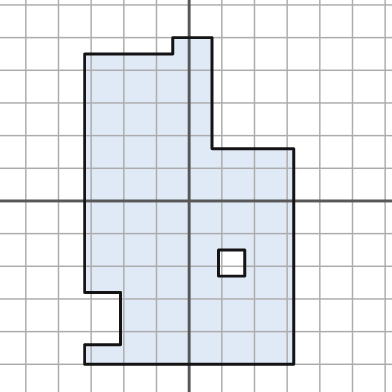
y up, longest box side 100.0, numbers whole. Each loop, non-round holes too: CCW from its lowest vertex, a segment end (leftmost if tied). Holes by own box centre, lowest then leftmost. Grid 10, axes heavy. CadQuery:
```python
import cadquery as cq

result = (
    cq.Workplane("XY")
    .moveTo(-32.0, -50.0)
    .lineTo(32.0, -50.0)
    .lineTo(32.0, 16.0)
    .lineTo(7.0, 16.0)
    .lineTo(7.0, 50.0)
    .lineTo(-5.0, 50.0)
    .lineTo(-5.0, 45.0)
    .lineTo(-32.0, 45.0)
    .lineTo(-32.0, -28.0)
    .lineTo(-21.0, -28.0)
    .lineTo(-21.0, -44.0)
    .lineTo(-32.0, -44.0)
    .close()
    .moveTo(9.0, -23.0)
    .lineTo(17.0, -23.0)
    .lineTo(17.0, -15.0)
    .lineTo(9.0, -15.0)
    .close()
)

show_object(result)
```